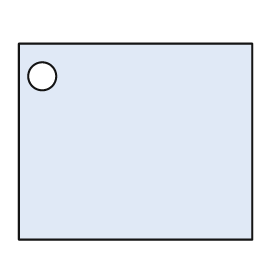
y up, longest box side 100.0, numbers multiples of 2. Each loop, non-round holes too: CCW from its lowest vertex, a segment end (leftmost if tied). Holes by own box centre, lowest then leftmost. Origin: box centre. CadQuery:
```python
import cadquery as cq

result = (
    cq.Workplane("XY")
    .moveTo(-50.0, -42.0)
    .lineTo(50.0, -42.0)
    .lineTo(50.0, 42.0)
    .lineTo(-50.0, 42.0)
    .close()
    .moveTo(-40.0, 28.0)
    .circle(6.0)
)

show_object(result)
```